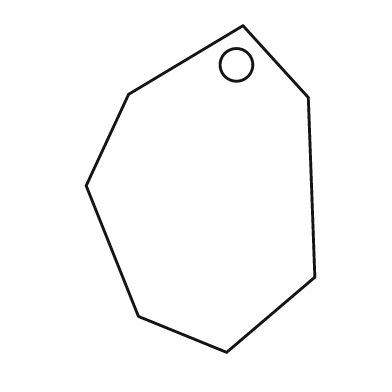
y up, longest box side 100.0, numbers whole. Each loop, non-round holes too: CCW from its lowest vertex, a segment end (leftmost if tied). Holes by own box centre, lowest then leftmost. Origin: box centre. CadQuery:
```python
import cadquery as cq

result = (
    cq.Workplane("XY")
    .moveTo(8.0, -50.0)
    .lineTo(35.0, -27.0)
    .lineTo(33.0, 28.0)
    .lineTo(13.0, 50.0)
    .lineTo(-22.0, 29.0)
    .lineTo(-35.0, 1.0)
    .lineTo(-19.0, -39.0)
    .close()
    .moveTo(11.0, 38.0)
    .circle(5.0)
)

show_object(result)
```